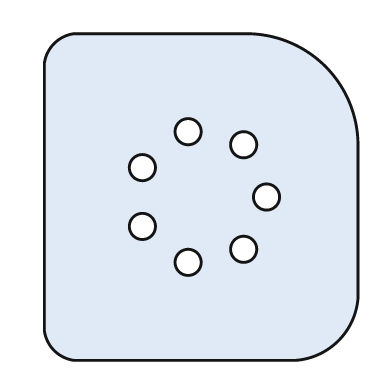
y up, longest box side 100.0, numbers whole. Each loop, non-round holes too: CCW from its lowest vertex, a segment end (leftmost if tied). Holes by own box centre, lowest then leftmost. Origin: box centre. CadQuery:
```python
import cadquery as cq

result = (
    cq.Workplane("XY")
    .moveTo(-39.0, -50.0)
    .lineTo(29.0, -50.0)
    .threePointArc((42.0, -44.0), (48.0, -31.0))
    .lineTo(48.0, 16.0)
    .threePointArc((38.0, 40.0), (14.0, 50.0))
    .lineTo(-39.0, 50.0)
    .threePointArc((-45.0, 47.0), (-48.0, 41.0))
    .lineTo(-48.0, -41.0)
    .threePointArc((-45.0, -47.0), (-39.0, -50.0))
    .close()
    .moveTo(-4.0, -20.0)
    .circle(4.0)
    .moveTo(13.0, -16.0)
    .circle(4.0)
    .moveTo(-18.0, -9.0)
    .circle(4.0)
    .moveTo(20.0, 0.0)
    .circle(4.0)
    .moveTo(-18.0, 9.0)
    .circle(4.0)
    .moveTo(13.0, 16.0)
    .circle(4.0)
    .moveTo(-4.0, 20.0)
    .circle(4.0)
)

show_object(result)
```